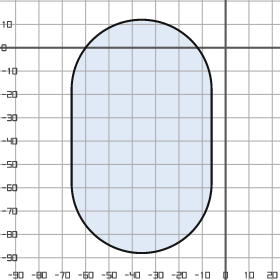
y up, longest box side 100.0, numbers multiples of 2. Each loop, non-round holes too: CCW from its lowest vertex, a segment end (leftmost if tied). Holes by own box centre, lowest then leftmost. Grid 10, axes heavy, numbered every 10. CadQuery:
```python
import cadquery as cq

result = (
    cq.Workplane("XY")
    .moveTo(-66.0, -58.0)
    .threePointArc((-36.0, -88.0), (-6.0, -58.0))
    .lineTo(-6.0, -18.0)
    .threePointArc((-36.0, 12.0), (-66.0, -18.0))
    .close()
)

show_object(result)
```